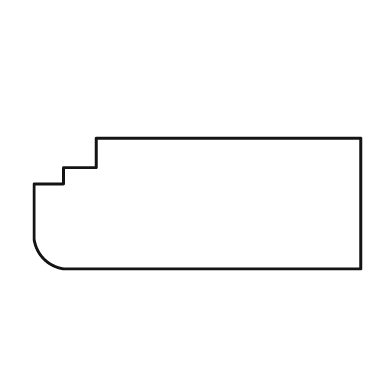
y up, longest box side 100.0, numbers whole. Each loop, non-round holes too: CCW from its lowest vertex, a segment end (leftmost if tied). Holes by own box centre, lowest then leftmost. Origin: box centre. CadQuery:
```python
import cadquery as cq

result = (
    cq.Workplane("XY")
    .moveTo(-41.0, -20.0)
    .lineTo(50.0, -20.0)
    .lineTo(50.0, 20.0)
    .lineTo(-31.0, 20.0)
    .lineTo(-31.0, 11.0)
    .lineTo(-41.0, 11.0)
    .lineTo(-41.0, 6.0)
    .lineTo(-50.0, 6.0)
    .lineTo(-50.0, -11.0)
    .threePointArc((-47.0, -17.0), (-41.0, -20.0))
    .close()
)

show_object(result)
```